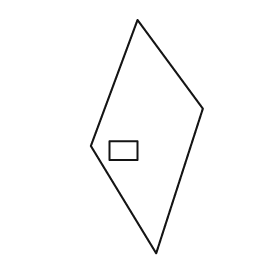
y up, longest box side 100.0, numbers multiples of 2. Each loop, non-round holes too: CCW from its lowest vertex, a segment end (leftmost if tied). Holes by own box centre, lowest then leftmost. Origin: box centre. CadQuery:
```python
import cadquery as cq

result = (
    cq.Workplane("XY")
    .moveTo(4.0, -50.0)
    .lineTo(24.0, 12.0)
    .lineTo(-4.0, 50.0)
    .lineTo(-24.0, -4.0)
    .close()
    .moveTo(-16.0, -10.0)
    .lineTo(-4.0, -10.0)
    .lineTo(-4.0, -2.0)
    .lineTo(-16.0, -2.0)
    .close()
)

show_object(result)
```